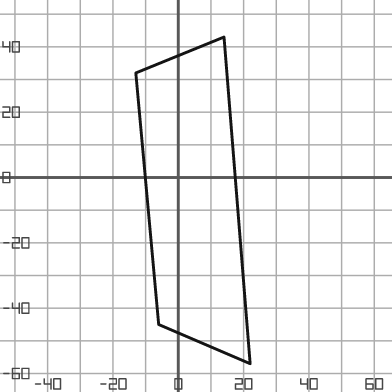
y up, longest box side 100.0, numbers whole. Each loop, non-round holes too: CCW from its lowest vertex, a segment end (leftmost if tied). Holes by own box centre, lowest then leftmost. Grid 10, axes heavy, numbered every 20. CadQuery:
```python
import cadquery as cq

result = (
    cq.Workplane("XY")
    .moveTo(22.0, -57.0)
    .lineTo(14.0, 43.0)
    .lineTo(-13.0, 32.0)
    .lineTo(-6.0, -45.0)
    .close()
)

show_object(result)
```